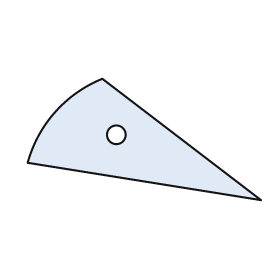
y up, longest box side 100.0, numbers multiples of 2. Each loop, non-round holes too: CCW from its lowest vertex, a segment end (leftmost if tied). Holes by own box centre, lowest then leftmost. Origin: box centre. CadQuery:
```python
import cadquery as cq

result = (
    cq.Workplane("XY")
    .moveTo(50.0, -26.0)
    .lineTo(-18.0, 26.0)
    .threePointArc((-38.0, 12.0), (-50.0, -10.0))
    .close()
    .moveTo(-12.0, 2.0)
    .circle(4.0)
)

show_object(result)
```